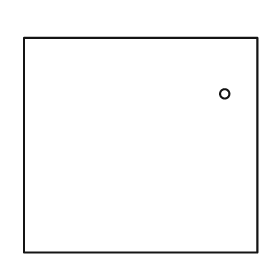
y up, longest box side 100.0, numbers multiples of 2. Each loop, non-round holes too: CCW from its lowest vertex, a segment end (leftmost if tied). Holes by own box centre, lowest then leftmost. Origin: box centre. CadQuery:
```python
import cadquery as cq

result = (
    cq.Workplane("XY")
    .moveTo(-50.0, -46.0)
    .lineTo(50.0, -46.0)
    .lineTo(50.0, 46.0)
    .lineTo(-50.0, 46.0)
    .close()
    .moveTo(36.0, 22.0)
    .circle(2.0)
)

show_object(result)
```